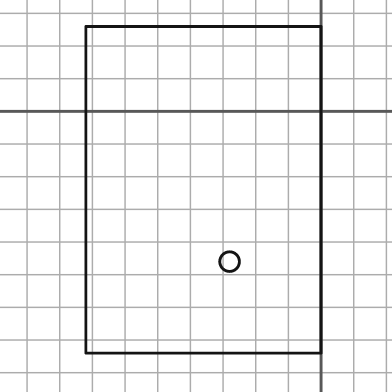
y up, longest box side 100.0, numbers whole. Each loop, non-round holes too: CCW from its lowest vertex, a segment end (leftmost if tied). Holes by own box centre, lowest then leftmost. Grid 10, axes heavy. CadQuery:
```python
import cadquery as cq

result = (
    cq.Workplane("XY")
    .moveTo(-72.0, -74.0)
    .lineTo(0.0, -74.0)
    .lineTo(0.0, 26.0)
    .lineTo(-72.0, 26.0)
    .close()
    .moveTo(-28.0, -46.0)
    .circle(3.0)
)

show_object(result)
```